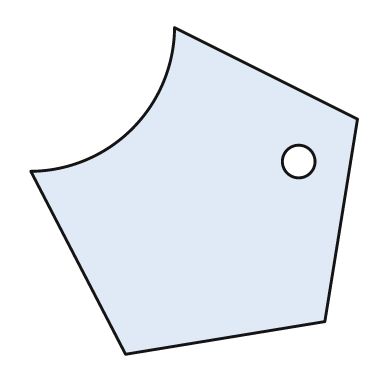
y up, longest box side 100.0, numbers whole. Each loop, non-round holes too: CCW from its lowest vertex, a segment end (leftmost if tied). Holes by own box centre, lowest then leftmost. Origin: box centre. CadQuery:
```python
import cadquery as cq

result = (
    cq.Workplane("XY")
    .moveTo(-21.0, -50.0)
    .lineTo(40.0, -40.0)
    .lineTo(50.0, 22.0)
    .lineTo(-6.0, 50.0)
    .threePointArc((-19.0, 19.0), (-50.0, 6.0))
    .close()
    .moveTo(32.0, 9.0)
    .circle(5.0)
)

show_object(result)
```